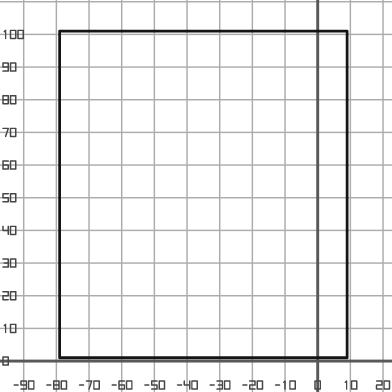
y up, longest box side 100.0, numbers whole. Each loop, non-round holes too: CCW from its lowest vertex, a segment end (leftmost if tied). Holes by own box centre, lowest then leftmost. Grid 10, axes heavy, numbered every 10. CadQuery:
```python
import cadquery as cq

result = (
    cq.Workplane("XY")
    .moveTo(-79.0, 1.0)
    .lineTo(9.0, 1.0)
    .lineTo(9.0, 101.0)
    .lineTo(-79.0, 101.0)
    .close()
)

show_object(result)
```